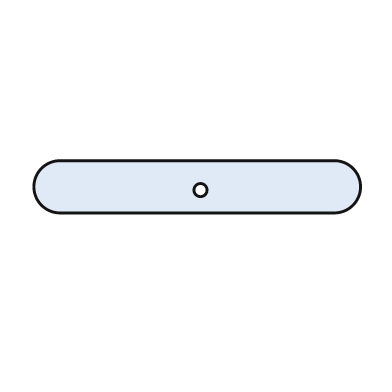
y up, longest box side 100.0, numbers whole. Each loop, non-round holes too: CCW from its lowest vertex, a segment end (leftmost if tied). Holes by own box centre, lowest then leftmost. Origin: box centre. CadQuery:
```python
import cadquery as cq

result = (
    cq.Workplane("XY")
    .moveTo(-42.0, -8.0)
    .lineTo(42.0, -8.0)
    .threePointArc((50.0, 0.0), (42.0, 8.0))
    .lineTo(-42.0, 8.0)
    .threePointArc((-50.0, 0.0), (-42.0, -8.0))
    .close()
    .moveTo(1.0, -1.0)
    .circle(2.0)
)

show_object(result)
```